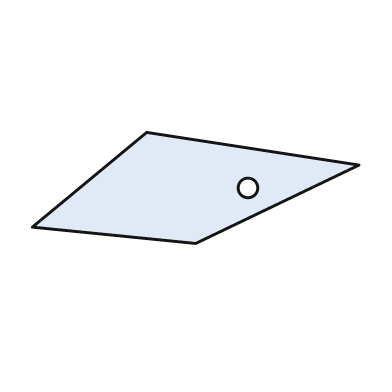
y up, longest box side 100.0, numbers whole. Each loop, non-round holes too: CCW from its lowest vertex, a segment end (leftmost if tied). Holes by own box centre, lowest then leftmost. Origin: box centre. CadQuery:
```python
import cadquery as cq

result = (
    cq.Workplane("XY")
    .moveTo(0.0, -17.0)
    .lineTo(50.0, 7.0)
    .lineTo(-15.0, 17.0)
    .lineTo(-50.0, -12.0)
    .close()
    .moveTo(16.0, 0.0)
    .circle(3.0)
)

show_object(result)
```